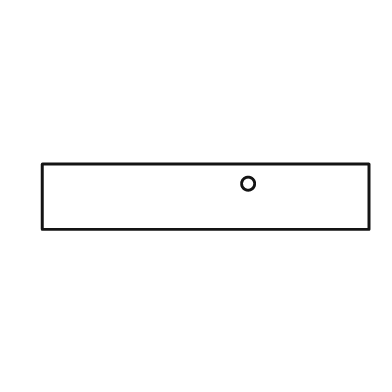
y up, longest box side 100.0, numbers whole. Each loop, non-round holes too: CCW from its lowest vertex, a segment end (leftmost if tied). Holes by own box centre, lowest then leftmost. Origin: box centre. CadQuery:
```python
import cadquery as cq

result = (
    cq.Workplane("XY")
    .moveTo(-50.0, -10.0)
    .lineTo(50.0, -10.0)
    .lineTo(50.0, 10.0)
    .lineTo(-50.0, 10.0)
    .close()
    .moveTo(13.0, 4.0)
    .circle(2.0)
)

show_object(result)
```